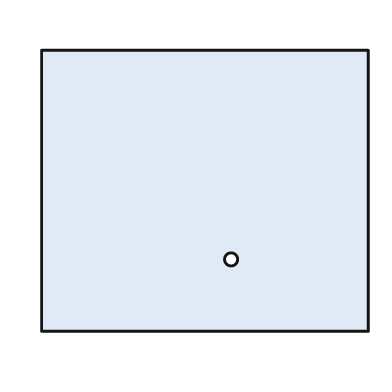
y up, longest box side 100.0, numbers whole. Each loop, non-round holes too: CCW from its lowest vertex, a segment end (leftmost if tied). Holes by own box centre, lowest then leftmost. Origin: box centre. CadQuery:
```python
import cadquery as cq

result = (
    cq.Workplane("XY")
    .moveTo(-50.0, -43.0)
    .lineTo(50.0, -43.0)
    .lineTo(50.0, 43.0)
    .lineTo(-50.0, 43.0)
    .close()
    .moveTo(8.0, -21.0)
    .circle(2.0)
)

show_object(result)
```